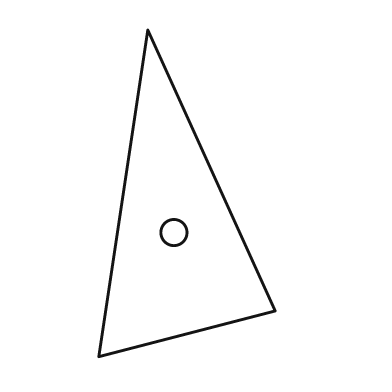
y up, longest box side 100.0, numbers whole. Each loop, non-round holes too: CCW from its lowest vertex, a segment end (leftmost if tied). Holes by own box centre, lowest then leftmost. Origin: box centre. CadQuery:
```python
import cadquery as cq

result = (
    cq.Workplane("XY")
    .moveTo(-27.0, -50.0)
    .lineTo(27.0, -36.0)
    .lineTo(-12.0, 50.0)
    .close()
    .moveTo(-4.0, -12.0)
    .circle(4.0)
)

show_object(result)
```